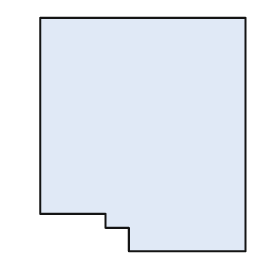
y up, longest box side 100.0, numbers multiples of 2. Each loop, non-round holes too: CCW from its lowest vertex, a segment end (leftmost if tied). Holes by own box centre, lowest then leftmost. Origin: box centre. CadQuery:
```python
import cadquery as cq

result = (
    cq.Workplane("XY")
    .moveTo(-6.0, -50.0)
    .lineTo(44.0, -50.0)
    .lineTo(44.0, 50.0)
    .lineTo(-44.0, 50.0)
    .lineTo(-44.0, -34.0)
    .lineTo(-16.0, -34.0)
    .lineTo(-16.0, -40.0)
    .lineTo(-6.0, -40.0)
    .close()
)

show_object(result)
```